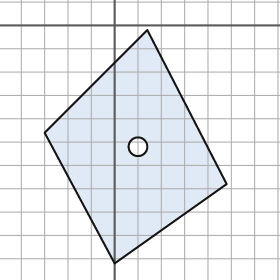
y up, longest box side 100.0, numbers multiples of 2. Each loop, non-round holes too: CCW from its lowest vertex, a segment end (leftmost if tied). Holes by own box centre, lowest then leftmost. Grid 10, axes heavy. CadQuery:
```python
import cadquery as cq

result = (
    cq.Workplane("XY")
    .moveTo(0.0, -102.0)
    .lineTo(48.0, -68.0)
    .lineTo(14.0, -2.0)
    .lineTo(-30.0, -46.0)
    .close()
    .moveTo(10.0, -52.0)
    .circle(4.0)
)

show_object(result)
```